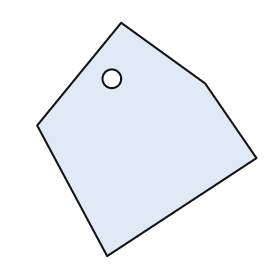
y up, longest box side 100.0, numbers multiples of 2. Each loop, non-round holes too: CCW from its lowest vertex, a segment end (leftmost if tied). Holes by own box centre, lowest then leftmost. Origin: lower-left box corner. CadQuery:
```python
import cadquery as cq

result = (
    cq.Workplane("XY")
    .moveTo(30.0, 0.0)
    .lineTo(94.0, 42.0)
    .lineTo(72.0, 74.0)
    .lineTo(36.0, 100.0)
    .lineTo(0.0, 56.0)
    .close()
    .moveTo(32.0, 76.0)
    .circle(4.0)
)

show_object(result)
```